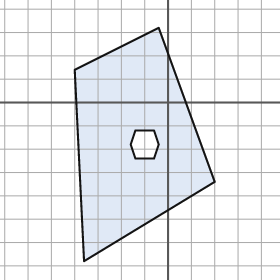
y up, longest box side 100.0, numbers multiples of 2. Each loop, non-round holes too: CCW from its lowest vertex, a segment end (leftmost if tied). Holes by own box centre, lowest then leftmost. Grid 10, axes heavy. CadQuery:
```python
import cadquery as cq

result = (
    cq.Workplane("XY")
    .moveTo(-36.0, -68.0)
    .lineTo(20.0, -34.0)
    .lineTo(-4.0, 32.0)
    .lineTo(-40.0, 14.0)
    .close()
    .moveTo(-14.0, -24.0)
    .lineTo(-6.0, -24.0)
    .lineTo(-4.0, -18.0)
    .lineTo(-6.0, -12.0)
    .lineTo(-14.0, -12.0)
    .lineTo(-16.0, -18.0)
    .close()
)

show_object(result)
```